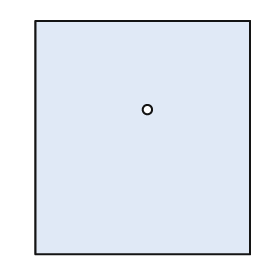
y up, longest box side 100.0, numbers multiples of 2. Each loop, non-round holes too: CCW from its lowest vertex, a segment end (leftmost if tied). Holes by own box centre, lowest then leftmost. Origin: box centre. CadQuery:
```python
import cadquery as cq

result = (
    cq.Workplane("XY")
    .moveTo(-46.0, -50.0)
    .lineTo(46.0, -50.0)
    .lineTo(46.0, 50.0)
    .lineTo(-46.0, 50.0)
    .close()
    .moveTo(2.0, 12.0)
    .circle(2.0)
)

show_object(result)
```